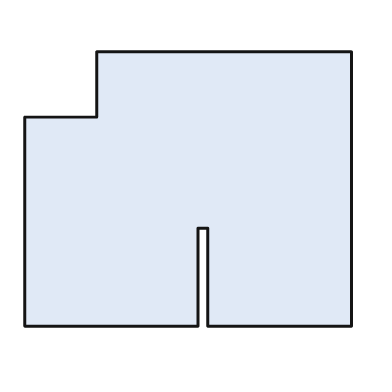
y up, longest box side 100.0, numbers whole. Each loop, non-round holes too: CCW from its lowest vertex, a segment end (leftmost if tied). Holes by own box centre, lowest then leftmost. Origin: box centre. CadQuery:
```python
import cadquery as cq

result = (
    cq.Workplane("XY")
    .moveTo(-50.0, -42.0)
    .lineTo(3.0, -42.0)
    .lineTo(3.0, -12.0)
    .lineTo(6.0, -12.0)
    .lineTo(6.0, -42.0)
    .lineTo(50.0, -42.0)
    .lineTo(50.0, 42.0)
    .lineTo(-28.0, 42.0)
    .lineTo(-28.0, 22.0)
    .lineTo(-50.0, 22.0)
    .close()
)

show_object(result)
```